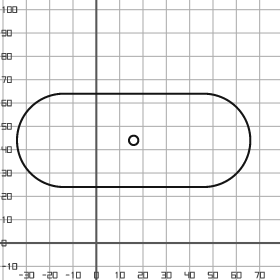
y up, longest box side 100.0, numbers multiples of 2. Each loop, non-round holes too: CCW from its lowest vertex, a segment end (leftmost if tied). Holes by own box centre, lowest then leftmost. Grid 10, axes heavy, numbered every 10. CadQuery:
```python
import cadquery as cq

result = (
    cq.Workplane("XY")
    .moveTo(-14.0, 24.0)
    .lineTo(46.0, 24.0)
    .threePointArc((66.0, 44.0), (46.0, 64.0))
    .lineTo(-14.0, 64.0)
    .threePointArc((-34.0, 44.0), (-14.0, 24.0))
    .close()
    .moveTo(16.0, 44.0)
    .circle(2.0)
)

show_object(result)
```